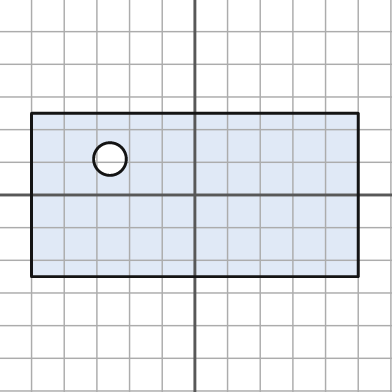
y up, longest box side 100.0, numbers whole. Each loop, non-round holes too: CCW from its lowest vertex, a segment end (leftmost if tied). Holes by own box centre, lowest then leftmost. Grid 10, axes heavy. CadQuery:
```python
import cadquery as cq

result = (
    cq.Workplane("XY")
    .moveTo(-50.0, -25.0)
    .lineTo(50.0, -25.0)
    .lineTo(50.0, 25.0)
    .lineTo(-50.0, 25.0)
    .close()
    .moveTo(-26.0, 11.0)
    .circle(5.0)
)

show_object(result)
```